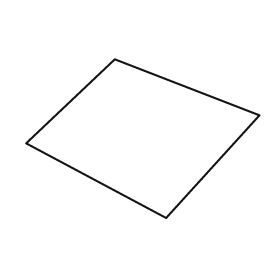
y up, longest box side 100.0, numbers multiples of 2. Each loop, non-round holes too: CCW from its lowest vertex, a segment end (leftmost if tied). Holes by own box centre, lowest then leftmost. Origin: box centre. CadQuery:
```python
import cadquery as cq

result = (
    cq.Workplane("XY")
    .moveTo(10.0, -34.0)
    .lineTo(50.0, 10.0)
    .lineTo(-12.0, 34.0)
    .lineTo(-50.0, -2.0)
    .close()
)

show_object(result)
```